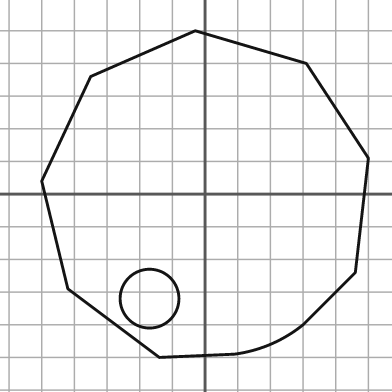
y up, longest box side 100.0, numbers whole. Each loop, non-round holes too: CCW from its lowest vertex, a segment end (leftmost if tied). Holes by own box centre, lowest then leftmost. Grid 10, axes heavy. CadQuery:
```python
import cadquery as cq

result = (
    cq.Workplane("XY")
    .moveTo(-14.0, -50.0)
    .lineTo(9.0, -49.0)
    .threePointArc((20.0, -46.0), (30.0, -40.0))
    .lineTo(46.0, -24.0)
    .lineTo(50.0, 11.0)
    .lineTo(31.0, 40.0)
    .lineTo(-3.0, 50.0)
    .lineTo(-35.0, 36.0)
    .lineTo(-50.0, 4.0)
    .lineTo(-42.0, -29.0)
    .close()
    .moveTo(-17.0, -32.0)
    .circle(9.0)
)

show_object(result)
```